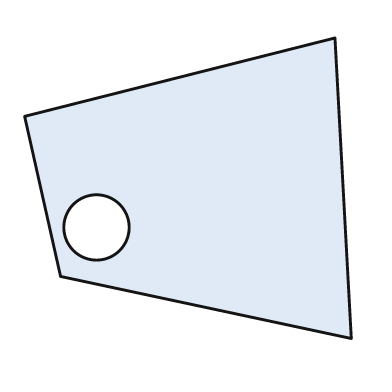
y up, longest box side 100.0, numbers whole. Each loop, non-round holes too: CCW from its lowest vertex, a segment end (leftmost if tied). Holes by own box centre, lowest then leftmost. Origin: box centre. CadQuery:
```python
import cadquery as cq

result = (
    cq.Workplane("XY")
    .moveTo(50.0, -46.0)
    .lineTo(45.0, 46.0)
    .lineTo(-50.0, 22.0)
    .lineTo(-39.0, -27.0)
    .close()
    .moveTo(-28.0, -12.0)
    .circle(10.0)
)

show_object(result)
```